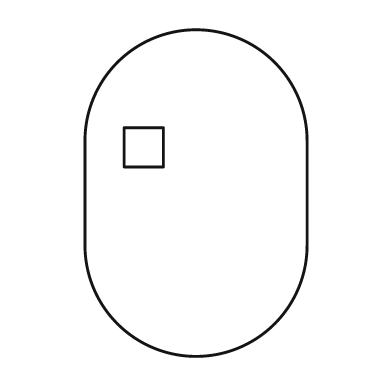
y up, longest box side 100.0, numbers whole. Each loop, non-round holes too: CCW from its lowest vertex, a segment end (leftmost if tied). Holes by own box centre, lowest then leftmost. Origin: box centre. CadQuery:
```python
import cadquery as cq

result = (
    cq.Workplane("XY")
    .moveTo(-34.0, -16.0)
    .threePointArc((0.0, -50.0), (34.0, -16.0))
    .lineTo(34.0, 16.0)
    .threePointArc((0.0, 50.0), (-34.0, 16.0))
    .close()
    .moveTo(-22.0, 8.0)
    .lineTo(-10.0, 8.0)
    .lineTo(-10.0, 20.0)
    .lineTo(-22.0, 20.0)
    .close()
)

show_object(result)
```